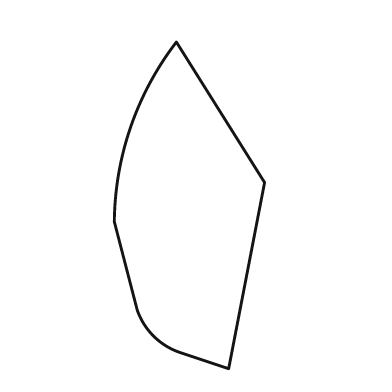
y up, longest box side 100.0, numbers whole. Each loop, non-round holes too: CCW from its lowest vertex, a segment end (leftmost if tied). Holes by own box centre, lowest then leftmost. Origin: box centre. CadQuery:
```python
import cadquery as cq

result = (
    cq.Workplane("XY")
    .moveTo(12.0, -50.0)
    .lineTo(23.0, 7.0)
    .lineTo(-4.0, 50.0)
    .threePointArc((-18.0, 24.0), (-23.0, -5.0))
    .lineTo(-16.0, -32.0)
    .threePointArc((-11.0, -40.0), (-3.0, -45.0))
    .close()
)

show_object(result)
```